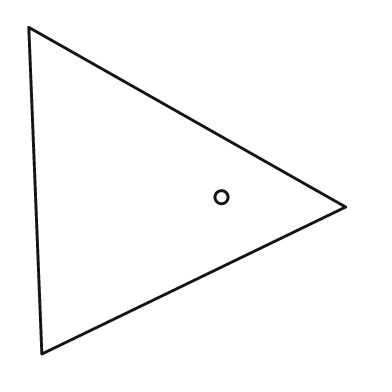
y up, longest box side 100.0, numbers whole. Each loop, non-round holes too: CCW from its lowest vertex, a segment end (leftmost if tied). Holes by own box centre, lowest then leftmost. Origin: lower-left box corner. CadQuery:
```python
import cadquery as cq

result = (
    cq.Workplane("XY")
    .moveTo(4.0, 0.0)
    .lineTo(97.0, 45.0)
    .lineTo(0.0, 100.0)
    .close()
    .moveTo(59.0, 48.0)
    .circle(2.0)
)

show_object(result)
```